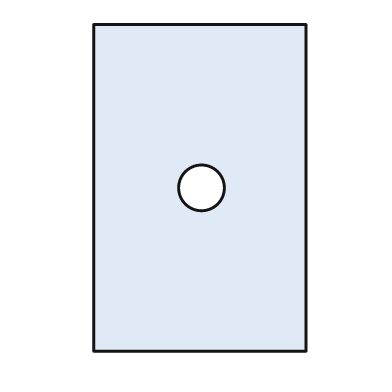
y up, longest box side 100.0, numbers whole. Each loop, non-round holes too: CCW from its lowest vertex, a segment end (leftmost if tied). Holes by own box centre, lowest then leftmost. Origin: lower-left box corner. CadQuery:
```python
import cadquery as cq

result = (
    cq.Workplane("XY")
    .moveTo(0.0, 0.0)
    .lineTo(65.0, 0.0)
    .lineTo(65.0, 100.0)
    .lineTo(0.0, 100.0)
    .close()
    .moveTo(33.0, 50.0)
    .circle(7.0)
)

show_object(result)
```